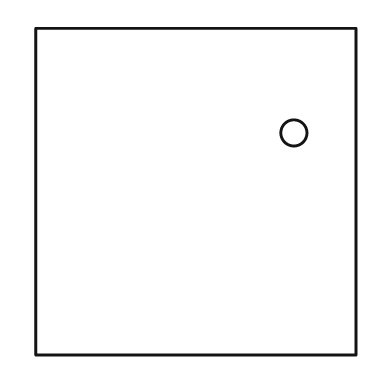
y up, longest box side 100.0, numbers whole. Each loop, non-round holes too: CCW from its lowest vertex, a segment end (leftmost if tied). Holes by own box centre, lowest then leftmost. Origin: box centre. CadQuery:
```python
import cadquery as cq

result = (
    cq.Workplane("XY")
    .moveTo(-49.0, -50.0)
    .lineTo(49.0, -50.0)
    .lineTo(49.0, 50.0)
    .lineTo(-49.0, 50.0)
    .close()
    .moveTo(30.0, 18.0)
    .circle(4.0)
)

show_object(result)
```